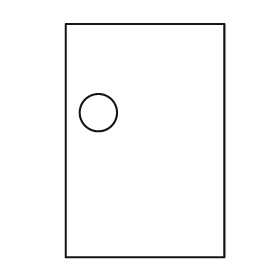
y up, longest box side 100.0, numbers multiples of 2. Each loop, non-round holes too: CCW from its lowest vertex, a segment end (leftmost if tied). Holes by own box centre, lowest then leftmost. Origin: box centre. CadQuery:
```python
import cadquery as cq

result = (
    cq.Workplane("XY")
    .moveTo(-34.0, -50.0)
    .lineTo(34.0, -50.0)
    .lineTo(34.0, 50.0)
    .lineTo(-34.0, 50.0)
    .close()
    .moveTo(-20.0, 12.0)
    .circle(8.0)
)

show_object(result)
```